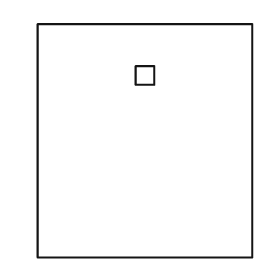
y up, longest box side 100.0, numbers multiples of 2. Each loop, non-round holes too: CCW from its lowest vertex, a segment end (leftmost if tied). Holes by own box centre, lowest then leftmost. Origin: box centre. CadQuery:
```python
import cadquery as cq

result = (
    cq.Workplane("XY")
    .moveTo(-46.0, -50.0)
    .lineTo(46.0, -50.0)
    .lineTo(46.0, 50.0)
    .lineTo(-46.0, 50.0)
    .close()
    .moveTo(-4.0, 24.0)
    .lineTo(4.0, 24.0)
    .lineTo(4.0, 32.0)
    .lineTo(-4.0, 32.0)
    .close()
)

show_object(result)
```